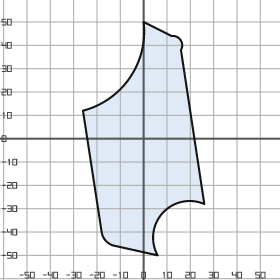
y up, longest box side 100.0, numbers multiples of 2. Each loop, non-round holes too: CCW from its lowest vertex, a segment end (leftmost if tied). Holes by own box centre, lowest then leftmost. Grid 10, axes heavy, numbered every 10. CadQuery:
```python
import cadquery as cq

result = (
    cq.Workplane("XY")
    .moveTo(6.0, -50.0)
    .threePointArc((8.0, -32.0), (26.0, -28.0))
    .lineTo(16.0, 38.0)
    .threePointArc((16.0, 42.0), (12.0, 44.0))
    .lineTo(0.0, 50.0)
    .threePointArc((-6.0, 26.0), (-26.0, 12.0))
    .lineTo(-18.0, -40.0)
    .threePointArc((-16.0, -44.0), (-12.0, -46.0))
    .close()
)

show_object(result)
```